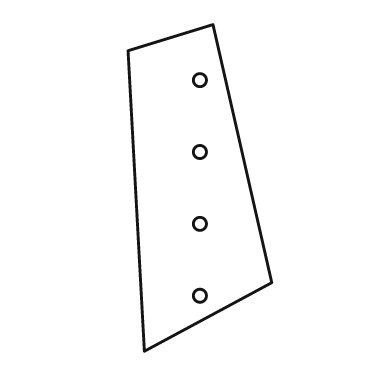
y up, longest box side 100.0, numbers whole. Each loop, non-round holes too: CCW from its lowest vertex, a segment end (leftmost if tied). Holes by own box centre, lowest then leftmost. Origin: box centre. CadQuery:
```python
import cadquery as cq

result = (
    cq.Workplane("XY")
    .moveTo(-17.0, -50.0)
    .lineTo(22.0, -29.0)
    .lineTo(4.0, 50.0)
    .lineTo(-22.0, 42.0)
    .close()
    .moveTo(0.0, -33.0)
    .circle(2.0)
    .moveTo(0.0, -11.0)
    .circle(2.0)
    .moveTo(0.0, 11.0)
    .circle(2.0)
    .moveTo(0.0, 33.0)
    .circle(2.0)
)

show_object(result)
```